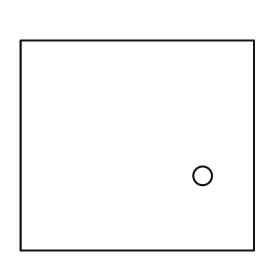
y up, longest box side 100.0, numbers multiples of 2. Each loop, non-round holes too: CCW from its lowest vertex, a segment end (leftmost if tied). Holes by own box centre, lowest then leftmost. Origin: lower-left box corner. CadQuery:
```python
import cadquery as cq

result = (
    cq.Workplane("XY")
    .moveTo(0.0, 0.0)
    .lineTo(100.0, 0.0)
    .lineTo(100.0, 90.0)
    .lineTo(0.0, 90.0)
    .close()
    .moveTo(78.0, 32.0)
    .circle(4.0)
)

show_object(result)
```